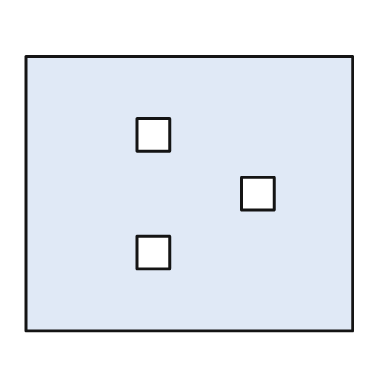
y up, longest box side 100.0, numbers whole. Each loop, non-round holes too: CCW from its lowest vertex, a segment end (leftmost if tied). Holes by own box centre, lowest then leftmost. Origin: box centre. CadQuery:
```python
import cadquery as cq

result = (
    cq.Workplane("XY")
    .moveTo(-50.0, -42.0)
    .lineTo(50.0, -42.0)
    .lineTo(50.0, 42.0)
    .lineTo(-50.0, 42.0)
    .close()
    .moveTo(-16.0, -23.0)
    .lineTo(-6.0, -23.0)
    .lineTo(-6.0, -13.0)
    .lineTo(-16.0, -13.0)
    .close()
    .moveTo(16.0, -5.0)
    .lineTo(26.0, -5.0)
    .lineTo(26.0, 5.0)
    .lineTo(16.0, 5.0)
    .close()
    .moveTo(-16.0, 13.0)
    .lineTo(-6.0, 13.0)
    .lineTo(-6.0, 23.0)
    .lineTo(-16.0, 23.0)
    .close()
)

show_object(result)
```